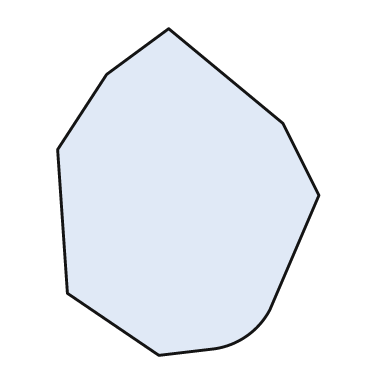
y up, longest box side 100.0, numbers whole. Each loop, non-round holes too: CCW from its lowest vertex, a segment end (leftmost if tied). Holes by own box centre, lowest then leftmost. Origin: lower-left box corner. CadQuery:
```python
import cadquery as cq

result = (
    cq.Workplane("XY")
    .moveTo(31.0, 0.0)
    .lineTo(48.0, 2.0)
    .threePointArc((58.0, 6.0), (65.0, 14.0))
    .lineTo(80.0, 49.0)
    .lineTo(69.0, 71.0)
    .lineTo(34.0, 100.0)
    .lineTo(15.0, 86.0)
    .lineTo(0.0, 63.0)
    .lineTo(3.0, 19.0)
    .close()
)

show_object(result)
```